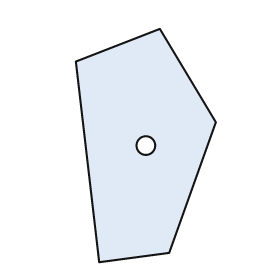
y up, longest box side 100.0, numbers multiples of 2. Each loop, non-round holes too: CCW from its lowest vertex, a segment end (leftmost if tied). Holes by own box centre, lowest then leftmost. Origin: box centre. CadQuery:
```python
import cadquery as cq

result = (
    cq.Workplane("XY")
    .moveTo(-20.0, -50.0)
    .lineTo(10.0, -46.0)
    .lineTo(30.0, 10.0)
    .lineTo(6.0, 50.0)
    .lineTo(-30.0, 36.0)
    .close()
    .moveTo(0.0, 0.0)
    .circle(4.0)
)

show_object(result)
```